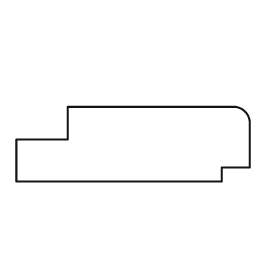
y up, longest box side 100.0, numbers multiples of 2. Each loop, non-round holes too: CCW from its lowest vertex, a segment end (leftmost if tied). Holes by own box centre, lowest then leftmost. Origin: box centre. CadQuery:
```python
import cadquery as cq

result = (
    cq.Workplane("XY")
    .moveTo(-50.0, -16.0)
    .lineTo(38.0, -16.0)
    .lineTo(38.0, -10.0)
    .lineTo(50.0, -10.0)
    .lineTo(50.0, 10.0)
    .threePointArc((48.0, 14.0), (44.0, 16.0))
    .lineTo(-28.0, 16.0)
    .lineTo(-28.0, 2.0)
    .lineTo(-50.0, 2.0)
    .close()
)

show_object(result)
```